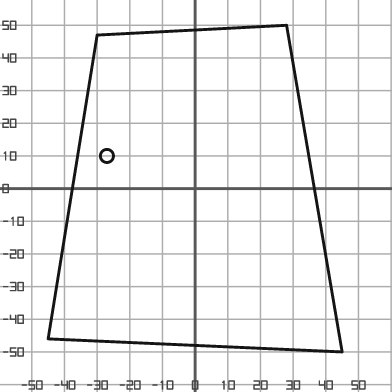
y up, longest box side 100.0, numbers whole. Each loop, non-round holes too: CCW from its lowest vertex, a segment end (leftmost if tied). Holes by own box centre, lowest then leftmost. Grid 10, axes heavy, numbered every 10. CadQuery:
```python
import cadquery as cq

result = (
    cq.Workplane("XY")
    .moveTo(45.0, -50.0)
    .lineTo(28.0, 50.0)
    .lineTo(-30.0, 47.0)
    .lineTo(-45.0, -46.0)
    .close()
    .moveTo(-27.0, 10.0)
    .circle(2.0)
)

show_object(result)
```